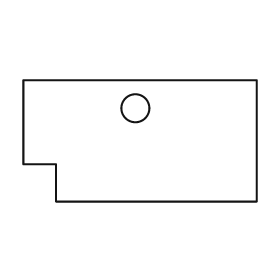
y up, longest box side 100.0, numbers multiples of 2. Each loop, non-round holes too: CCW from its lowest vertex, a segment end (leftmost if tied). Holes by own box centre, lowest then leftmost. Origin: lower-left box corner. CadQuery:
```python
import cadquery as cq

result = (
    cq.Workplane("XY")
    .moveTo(14.0, 0.0)
    .lineTo(100.0, 0.0)
    .lineTo(100.0, 52.0)
    .lineTo(0.0, 52.0)
    .lineTo(0.0, 16.0)
    .lineTo(14.0, 16.0)
    .close()
    .moveTo(48.0, 40.0)
    .circle(6.0)
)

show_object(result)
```